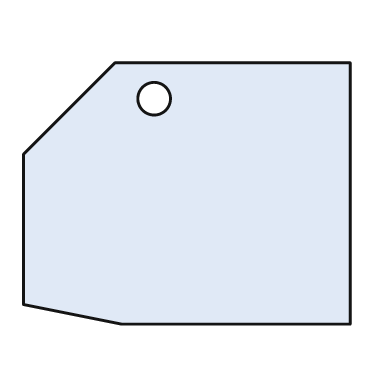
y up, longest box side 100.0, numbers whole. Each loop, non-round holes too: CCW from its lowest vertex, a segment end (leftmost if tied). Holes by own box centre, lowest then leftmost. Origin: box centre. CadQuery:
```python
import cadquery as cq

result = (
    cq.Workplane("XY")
    .moveTo(-20.0, -40.0)
    .lineTo(50.0, -40.0)
    .lineTo(50.0, 40.0)
    .lineTo(-22.0, 40.0)
    .lineTo(-50.0, 12.0)
    .lineTo(-50.0, -34.0)
    .close()
    .moveTo(-10.0, 29.0)
    .circle(5.0)
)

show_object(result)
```